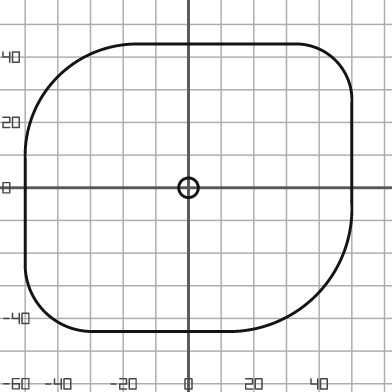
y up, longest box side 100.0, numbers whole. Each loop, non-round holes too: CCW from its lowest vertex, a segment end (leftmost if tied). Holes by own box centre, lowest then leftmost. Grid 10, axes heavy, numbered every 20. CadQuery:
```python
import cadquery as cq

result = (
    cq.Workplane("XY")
    .moveTo(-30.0, -44.0)
    .lineTo(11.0, -44.0)
    .threePointArc((39.0, -33.0), (50.0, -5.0))
    .lineTo(50.0, 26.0)
    .threePointArc((45.0, 39.0), (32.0, 44.0))
    .lineTo(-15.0, 44.0)
    .threePointArc((-40.0, 34.0), (-50.0, 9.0))
    .lineTo(-50.0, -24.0)
    .threePointArc((-44.0, -38.0), (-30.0, -44.0))
    .close()
    .moveTo(0.0, 0.0)
    .circle(3.0)
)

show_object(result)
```